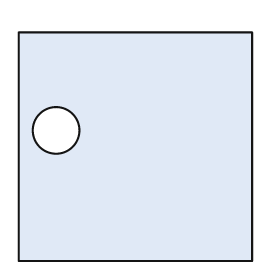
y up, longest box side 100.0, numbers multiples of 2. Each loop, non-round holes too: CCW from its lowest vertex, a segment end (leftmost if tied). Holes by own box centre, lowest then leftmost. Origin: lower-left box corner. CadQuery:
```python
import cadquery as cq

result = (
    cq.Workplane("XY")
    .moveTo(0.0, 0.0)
    .lineTo(100.0, 0.0)
    .lineTo(100.0, 98.0)
    .lineTo(0.0, 98.0)
    .close()
    .moveTo(16.0, 56.0)
    .circle(10.0)
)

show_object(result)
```